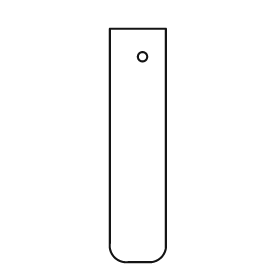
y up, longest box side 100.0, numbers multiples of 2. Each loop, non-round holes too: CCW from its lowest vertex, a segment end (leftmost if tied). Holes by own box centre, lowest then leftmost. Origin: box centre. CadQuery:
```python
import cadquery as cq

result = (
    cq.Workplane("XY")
    .moveTo(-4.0, -50.0)
    .lineTo(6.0, -50.0)
    .threePointArc((10.0, -48.0), (12.0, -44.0))
    .lineTo(12.0, 50.0)
    .lineTo(-12.0, 50.0)
    .lineTo(-12.0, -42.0)
    .threePointArc((-10.0, -48.0), (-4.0, -50.0))
    .close()
    .moveTo(2.0, 38.0)
    .circle(2.0)
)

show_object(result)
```